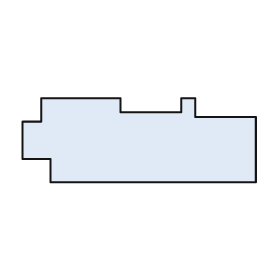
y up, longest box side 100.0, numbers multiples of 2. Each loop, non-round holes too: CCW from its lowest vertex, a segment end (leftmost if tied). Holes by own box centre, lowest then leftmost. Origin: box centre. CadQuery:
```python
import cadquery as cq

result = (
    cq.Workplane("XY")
    .moveTo(-38.0, -18.0)
    .lineTo(50.0, -18.0)
    .lineTo(50.0, 10.0)
    .lineTo(24.0, 10.0)
    .lineTo(24.0, 18.0)
    .lineTo(18.0, 18.0)
    .lineTo(18.0, 12.0)
    .lineTo(-8.0, 12.0)
    .lineTo(-8.0, 18.0)
    .lineTo(-42.0, 18.0)
    .lineTo(-42.0, 8.0)
    .lineTo(-50.0, 8.0)
    .lineTo(-50.0, -8.0)
    .lineTo(-38.0, -8.0)
    .close()
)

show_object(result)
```